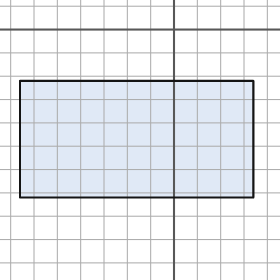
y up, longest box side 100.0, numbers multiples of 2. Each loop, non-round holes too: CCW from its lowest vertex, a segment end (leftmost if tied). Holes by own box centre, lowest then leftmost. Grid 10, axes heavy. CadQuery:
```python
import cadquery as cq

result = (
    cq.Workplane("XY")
    .moveTo(-66.0, -72.0)
    .lineTo(34.0, -72.0)
    .lineTo(34.0, -22.0)
    .lineTo(-66.0, -22.0)
    .close()
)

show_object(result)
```